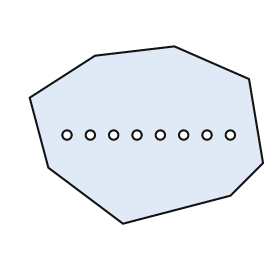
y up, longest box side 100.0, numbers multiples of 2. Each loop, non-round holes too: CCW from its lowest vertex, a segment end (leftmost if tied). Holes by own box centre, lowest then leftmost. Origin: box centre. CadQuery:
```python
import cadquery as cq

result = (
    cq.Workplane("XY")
    .moveTo(-10.0, -38.0)
    .lineTo(36.0, -26.0)
    .lineTo(50.0, -12.0)
    .lineTo(44.0, 24.0)
    .lineTo(12.0, 38.0)
    .lineTo(-22.0, 34.0)
    .lineTo(-50.0, 16.0)
    .lineTo(-42.0, -14.0)
    .close()
    .moveTo(-34.0, 0.0)
    .circle(2.0)
    .moveTo(-24.0, 0.0)
    .circle(2.0)
    .moveTo(-14.0, 0.0)
    .circle(2.0)
    .moveTo(-4.0, 0.0)
    .circle(2.0)
    .moveTo(6.0, 0.0)
    .circle(2.0)
    .moveTo(16.0, 0.0)
    .circle(2.0)
    .moveTo(26.0, 0.0)
    .circle(2.0)
    .moveTo(36.0, 0.0)
    .circle(2.0)
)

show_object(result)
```